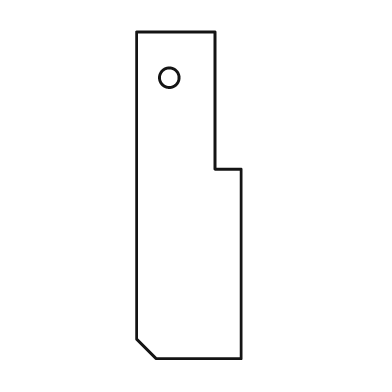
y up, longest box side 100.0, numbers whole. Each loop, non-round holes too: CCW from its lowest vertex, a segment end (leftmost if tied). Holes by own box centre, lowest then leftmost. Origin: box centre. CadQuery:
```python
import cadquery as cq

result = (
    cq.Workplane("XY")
    .moveTo(-10.0, -50.0)
    .lineTo(16.0, -50.0)
    .lineTo(16.0, 8.0)
    .lineTo(8.0, 8.0)
    .lineTo(8.0, 50.0)
    .lineTo(-16.0, 50.0)
    .lineTo(-16.0, -44.0)
    .close()
    .moveTo(-6.0, 36.0)
    .circle(3.0)
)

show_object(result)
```